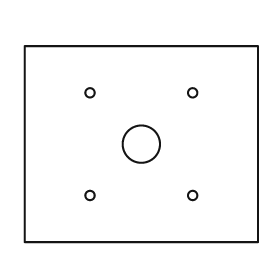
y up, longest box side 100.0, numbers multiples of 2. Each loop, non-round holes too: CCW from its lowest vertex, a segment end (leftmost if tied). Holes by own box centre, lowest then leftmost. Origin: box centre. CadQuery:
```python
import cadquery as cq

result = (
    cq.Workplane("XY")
    .moveTo(-50.0, -42.0)
    .lineTo(50.0, -42.0)
    .lineTo(50.0, 42.0)
    .lineTo(-50.0, 42.0)
    .close()
    .moveTo(-22.0, -22.0)
    .circle(2.0)
    .moveTo(22.0, -22.0)
    .circle(2.0)
    .moveTo(0.0, 0.0)
    .circle(8.0)
    .moveTo(-22.0, 22.0)
    .circle(2.0)
    .moveTo(22.0, 22.0)
    .circle(2.0)
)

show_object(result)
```